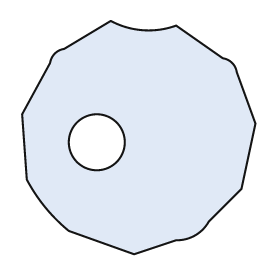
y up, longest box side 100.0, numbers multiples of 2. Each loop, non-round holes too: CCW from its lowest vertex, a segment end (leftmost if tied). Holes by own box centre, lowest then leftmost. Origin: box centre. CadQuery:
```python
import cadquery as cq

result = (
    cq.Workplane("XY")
    .moveTo(-2.0, -50.0)
    .lineTo(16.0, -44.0)
    .threePointArc((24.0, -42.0), (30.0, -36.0))
    .lineTo(44.0, -22.0)
    .lineTo(50.0, 6.0)
    .lineTo(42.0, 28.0)
    .threePointArc((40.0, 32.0), (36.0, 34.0))
    .lineTo(16.0, 48.0)
    .threePointArc((2.0, 46.0), (-12.0, 50.0))
    .lineTo(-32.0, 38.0)
    .threePointArc((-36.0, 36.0), (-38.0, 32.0))
    .lineTo(-50.0, 10.0)
    .lineTo(-48.0, -18.0)
    .threePointArc((-40.0, -30.0), (-30.0, -40.0))
    .close()
    .moveTo(-18.0, -2.0)
    .circle(12.0)
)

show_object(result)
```